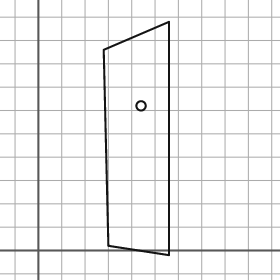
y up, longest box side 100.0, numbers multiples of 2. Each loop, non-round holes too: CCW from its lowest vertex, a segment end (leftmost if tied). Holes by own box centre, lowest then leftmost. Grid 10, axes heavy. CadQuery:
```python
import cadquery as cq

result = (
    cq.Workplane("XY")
    .moveTo(56.0, -2.0)
    .lineTo(56.0, 98.0)
    .lineTo(28.0, 86.0)
    .lineTo(30.0, 2.0)
    .close()
    .moveTo(44.0, 62.0)
    .circle(2.0)
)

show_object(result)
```